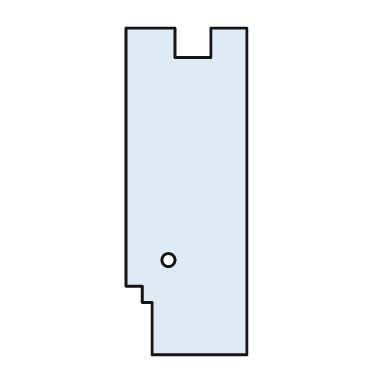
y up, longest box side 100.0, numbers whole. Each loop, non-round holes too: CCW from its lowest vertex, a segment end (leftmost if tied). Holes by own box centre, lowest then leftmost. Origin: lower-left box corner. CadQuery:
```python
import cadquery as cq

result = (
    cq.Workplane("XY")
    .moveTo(8.0, 0.0)
    .lineTo(37.0, 0.0)
    .lineTo(37.0, 100.0)
    .lineTo(26.0, 100.0)
    .lineTo(26.0, 91.0)
    .lineTo(15.0, 91.0)
    .lineTo(15.0, 100.0)
    .lineTo(0.0, 100.0)
    .lineTo(0.0, 21.0)
    .lineTo(5.0, 21.0)
    .lineTo(5.0, 16.0)
    .lineTo(8.0, 16.0)
    .close()
    .moveTo(13.0, 29.0)
    .circle(2.0)
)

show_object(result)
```